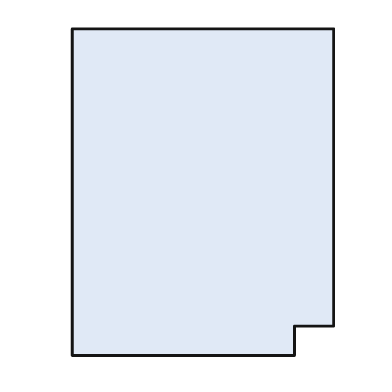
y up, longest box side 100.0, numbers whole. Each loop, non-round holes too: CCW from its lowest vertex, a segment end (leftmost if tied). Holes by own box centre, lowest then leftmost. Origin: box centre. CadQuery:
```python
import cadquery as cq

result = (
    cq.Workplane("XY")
    .moveTo(-40.0, -50.0)
    .lineTo(28.0, -50.0)
    .lineTo(28.0, -41.0)
    .lineTo(40.0, -41.0)
    .lineTo(40.0, 50.0)
    .lineTo(-40.0, 50.0)
    .close()
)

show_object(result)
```